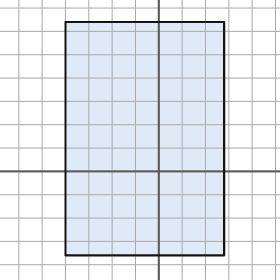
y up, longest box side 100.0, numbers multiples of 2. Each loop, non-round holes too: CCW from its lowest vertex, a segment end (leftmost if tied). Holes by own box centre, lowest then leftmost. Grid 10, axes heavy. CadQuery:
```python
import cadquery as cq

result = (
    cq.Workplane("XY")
    .moveTo(-40.0, -36.0)
    .lineTo(28.0, -36.0)
    .lineTo(28.0, 64.0)
    .lineTo(-40.0, 64.0)
    .close()
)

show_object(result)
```